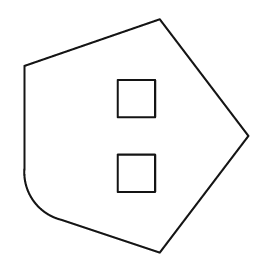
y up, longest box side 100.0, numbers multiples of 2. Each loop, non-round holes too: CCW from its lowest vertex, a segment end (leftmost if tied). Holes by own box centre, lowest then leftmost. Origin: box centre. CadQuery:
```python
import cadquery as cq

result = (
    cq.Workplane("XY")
    .moveTo(10.0, -50.0)
    .lineTo(48.0, 0.0)
    .lineTo(10.0, 50.0)
    .lineTo(-48.0, 30.0)
    .lineTo(-48.0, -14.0)
    .threePointArc((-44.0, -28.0), (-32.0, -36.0))
    .close()
    .moveTo(-8.0, -24.0)
    .lineTo(8.0, -24.0)
    .lineTo(8.0, -8.0)
    .lineTo(-8.0, -8.0)
    .close()
    .moveTo(-8.0, 8.0)
    .lineTo(8.0, 8.0)
    .lineTo(8.0, 24.0)
    .lineTo(-8.0, 24.0)
    .close()
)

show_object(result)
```